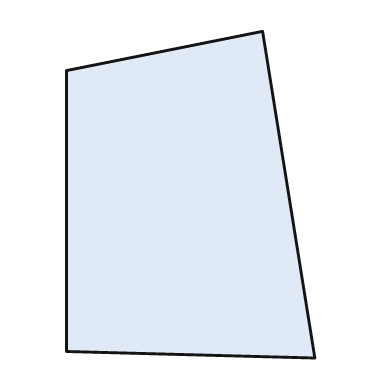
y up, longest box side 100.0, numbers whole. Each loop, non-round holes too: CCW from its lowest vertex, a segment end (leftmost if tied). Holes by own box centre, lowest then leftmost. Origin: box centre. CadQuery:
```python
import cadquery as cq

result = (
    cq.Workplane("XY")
    .moveTo(38.0, -50.0)
    .lineTo(22.0, 50.0)
    .lineTo(-38.0, 38.0)
    .lineTo(-38.0, -48.0)
    .close()
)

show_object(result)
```